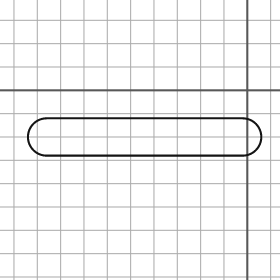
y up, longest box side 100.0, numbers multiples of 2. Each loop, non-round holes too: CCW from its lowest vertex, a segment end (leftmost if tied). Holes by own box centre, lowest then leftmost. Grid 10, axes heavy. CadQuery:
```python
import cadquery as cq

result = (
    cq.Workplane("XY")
    .moveTo(-86.0, -28.0)
    .lineTo(-2.0, -28.0)
    .threePointArc((6.0, -20.0), (-2.0, -12.0))
    .lineTo(-86.0, -12.0)
    .threePointArc((-94.0, -20.0), (-86.0, -28.0))
    .close()
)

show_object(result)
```